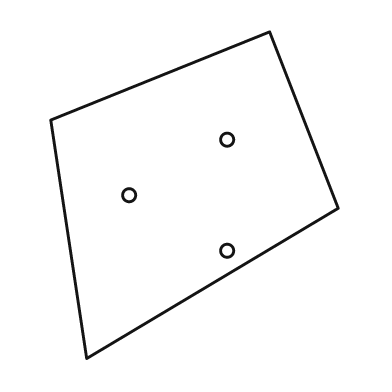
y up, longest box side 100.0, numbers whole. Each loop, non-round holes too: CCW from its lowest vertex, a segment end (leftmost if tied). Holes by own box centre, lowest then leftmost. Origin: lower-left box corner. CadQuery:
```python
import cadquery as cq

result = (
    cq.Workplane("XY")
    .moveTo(11.0, 0.0)
    .lineTo(88.0, 46.0)
    .lineTo(67.0, 100.0)
    .lineTo(0.0, 73.0)
    .close()
    .moveTo(54.0, 33.0)
    .circle(2.0)
    .moveTo(24.0, 50.0)
    .circle(2.0)
    .moveTo(54.0, 67.0)
    .circle(2.0)
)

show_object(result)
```